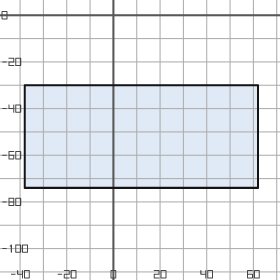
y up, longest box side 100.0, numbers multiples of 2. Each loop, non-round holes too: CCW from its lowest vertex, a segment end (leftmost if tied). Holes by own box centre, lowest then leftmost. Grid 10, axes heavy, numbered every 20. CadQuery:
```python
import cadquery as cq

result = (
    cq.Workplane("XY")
    .moveTo(-38.0, -74.0)
    .lineTo(62.0, -74.0)
    .lineTo(62.0, -30.0)
    .lineTo(-38.0, -30.0)
    .close()
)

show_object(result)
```